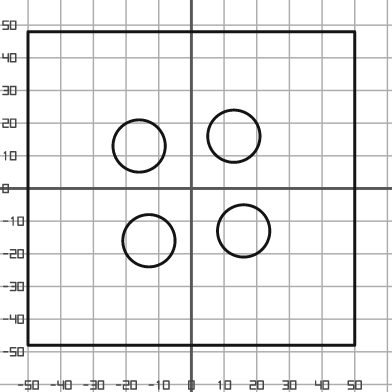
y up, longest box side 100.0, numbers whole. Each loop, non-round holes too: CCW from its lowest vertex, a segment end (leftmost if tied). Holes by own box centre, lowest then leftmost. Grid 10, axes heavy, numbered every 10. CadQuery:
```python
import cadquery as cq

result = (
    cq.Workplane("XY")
    .moveTo(-50.0, -48.0)
    .lineTo(50.0, -48.0)
    .lineTo(50.0, 48.0)
    .lineTo(-50.0, 48.0)
    .close()
    .moveTo(-13.0, -16.0)
    .circle(8.0)
    .moveTo(16.0, -13.0)
    .circle(8.0)
    .moveTo(-16.0, 13.0)
    .circle(8.0)
    .moveTo(13.0, 16.0)
    .circle(8.0)
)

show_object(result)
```